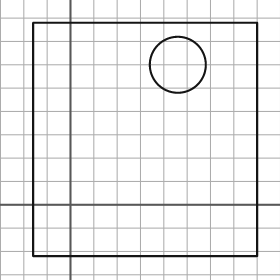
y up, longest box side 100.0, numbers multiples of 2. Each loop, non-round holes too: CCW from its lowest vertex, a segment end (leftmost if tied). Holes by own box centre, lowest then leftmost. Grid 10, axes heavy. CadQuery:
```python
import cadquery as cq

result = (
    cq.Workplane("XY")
    .moveTo(-16.0, -22.0)
    .lineTo(80.0, -22.0)
    .lineTo(80.0, 78.0)
    .lineTo(-16.0, 78.0)
    .close()
    .moveTo(46.0, 60.0)
    .circle(12.0)
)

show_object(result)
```